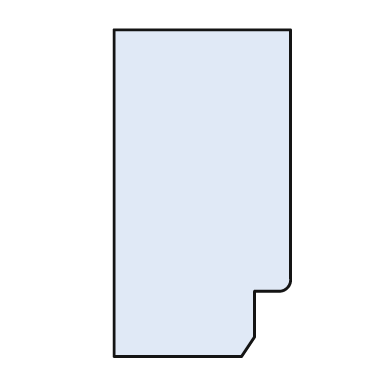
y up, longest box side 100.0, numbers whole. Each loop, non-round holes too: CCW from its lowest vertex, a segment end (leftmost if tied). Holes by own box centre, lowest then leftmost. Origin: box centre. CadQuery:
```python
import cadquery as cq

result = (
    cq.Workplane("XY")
    .moveTo(-27.0, -50.0)
    .lineTo(12.0, -50.0)
    .lineTo(16.0, -44.0)
    .lineTo(16.0, -30.0)
    .lineTo(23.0, -30.0)
    .threePointArc((26.0, -29.0), (27.0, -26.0))
    .lineTo(27.0, 50.0)
    .lineTo(-27.0, 50.0)
    .close()
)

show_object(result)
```